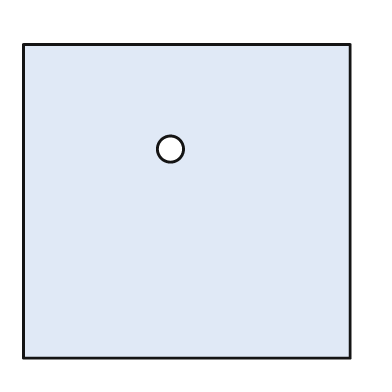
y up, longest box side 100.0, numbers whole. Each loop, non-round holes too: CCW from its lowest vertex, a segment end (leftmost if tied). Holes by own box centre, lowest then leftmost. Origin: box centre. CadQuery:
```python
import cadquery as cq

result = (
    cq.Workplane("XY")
    .moveTo(-50.0, -48.0)
    .lineTo(50.0, -48.0)
    .lineTo(50.0, 48.0)
    .lineTo(-50.0, 48.0)
    .close()
    .moveTo(-5.0, 16.0)
    .circle(4.0)
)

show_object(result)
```